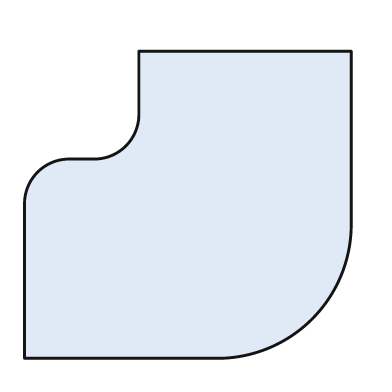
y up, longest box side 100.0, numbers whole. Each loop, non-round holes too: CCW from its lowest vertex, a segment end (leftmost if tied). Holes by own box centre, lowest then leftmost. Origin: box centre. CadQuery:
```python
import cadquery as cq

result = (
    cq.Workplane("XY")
    .moveTo(-50.0, -47.0)
    .lineTo(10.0, -47.0)
    .threePointArc((38.0, -35.0), (50.0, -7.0))
    .lineTo(50.0, 47.0)
    .lineTo(-15.0, 47.0)
    .lineTo(-15.0, 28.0)
    .threePointArc((-19.0, 18.0), (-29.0, 14.0))
    .lineTo(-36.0, 14.0)
    .threePointArc((-46.0, 10.0), (-50.0, 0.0))
    .close()
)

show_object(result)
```